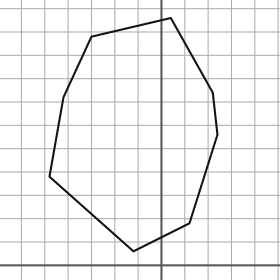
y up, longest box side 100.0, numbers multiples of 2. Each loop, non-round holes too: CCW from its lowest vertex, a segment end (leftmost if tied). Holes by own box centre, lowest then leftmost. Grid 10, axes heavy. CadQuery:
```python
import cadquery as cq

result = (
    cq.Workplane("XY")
    .moveTo(-12.0, 6.0)
    .lineTo(12.0, 18.0)
    .lineTo(24.0, 56.0)
    .lineTo(22.0, 74.0)
    .lineTo(4.0, 106.0)
    .lineTo(-30.0, 98.0)
    .lineTo(-42.0, 72.0)
    .lineTo(-48.0, 38.0)
    .close()
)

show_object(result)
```